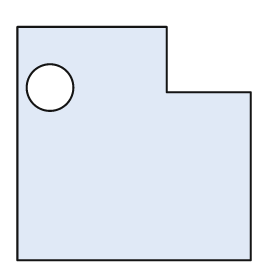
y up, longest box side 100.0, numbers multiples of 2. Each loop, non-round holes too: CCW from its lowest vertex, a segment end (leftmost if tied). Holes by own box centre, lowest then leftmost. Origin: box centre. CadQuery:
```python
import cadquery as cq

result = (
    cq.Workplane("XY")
    .moveTo(-50.0, -50.0)
    .lineTo(50.0, -50.0)
    .lineTo(50.0, 22.0)
    .lineTo(14.0, 22.0)
    .lineTo(14.0, 50.0)
    .lineTo(-50.0, 50.0)
    .close()
    .moveTo(-36.0, 24.0)
    .circle(10.0)
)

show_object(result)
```